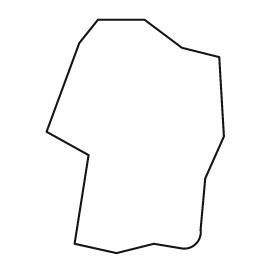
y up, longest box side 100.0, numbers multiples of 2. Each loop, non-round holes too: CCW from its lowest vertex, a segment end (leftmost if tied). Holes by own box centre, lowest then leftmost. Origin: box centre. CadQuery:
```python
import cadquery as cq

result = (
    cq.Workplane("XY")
    .moveTo(-8.0, -50.0)
    .lineTo(8.0, -46.0)
    .lineTo(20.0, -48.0)
    .threePointArc((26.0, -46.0), (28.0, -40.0))
    .lineTo(30.0, -18.0)
    .lineTo(38.0, 0.0)
    .lineTo(36.0, 34.0)
    .lineTo(20.0, 38.0)
    .lineTo(4.0, 50.0)
    .lineTo(-16.0, 50.0)
    .lineTo(-24.0, 40.0)
    .lineTo(-38.0, 2.0)
    .lineTo(-20.0, -8.0)
    .lineTo(-26.0, -46.0)
    .close()
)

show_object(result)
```